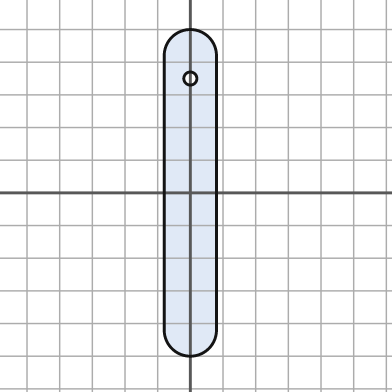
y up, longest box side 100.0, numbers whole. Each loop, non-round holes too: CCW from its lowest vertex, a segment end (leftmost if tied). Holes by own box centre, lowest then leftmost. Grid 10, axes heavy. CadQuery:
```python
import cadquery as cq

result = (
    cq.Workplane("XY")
    .moveTo(-8.0, -42.0)
    .threePointArc((0.0, -50.0), (8.0, -42.0))
    .lineTo(8.0, 42.0)
    .threePointArc((0.0, 50.0), (-8.0, 42.0))
    .close()
    .moveTo(0.0, 35.0)
    .circle(2.0)
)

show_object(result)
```